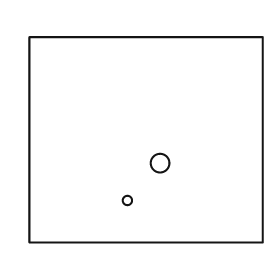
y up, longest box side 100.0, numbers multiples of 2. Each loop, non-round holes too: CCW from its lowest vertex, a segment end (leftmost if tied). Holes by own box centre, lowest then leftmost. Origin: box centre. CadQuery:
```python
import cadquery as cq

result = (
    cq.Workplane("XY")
    .moveTo(-50.0, -44.0)
    .lineTo(50.0, -44.0)
    .lineTo(50.0, 44.0)
    .lineTo(-50.0, 44.0)
    .close()
    .moveTo(-8.0, -26.0)
    .circle(2.0)
    .moveTo(6.0, -10.0)
    .circle(4.0)
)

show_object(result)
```